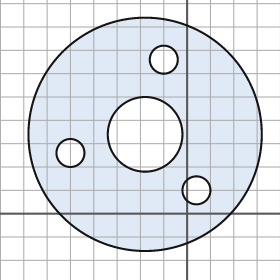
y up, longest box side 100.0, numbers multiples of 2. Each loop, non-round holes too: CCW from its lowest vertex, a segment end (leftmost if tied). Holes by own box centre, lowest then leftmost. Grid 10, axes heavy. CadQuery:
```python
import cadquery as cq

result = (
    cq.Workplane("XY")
    .moveTo(-18.0, 34.0)
    .circle(50.0)
    .moveTo(4.0, 10.0)
    .circle(6.0)
    .moveTo(-50.0, 26.0)
    .circle(6.0)
    .moveTo(-18.0, 34.0)
    .circle(16.0)
    .moveTo(-10.0, 66.0)
    .circle(6.0)
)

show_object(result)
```